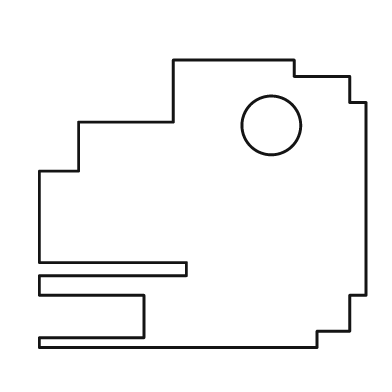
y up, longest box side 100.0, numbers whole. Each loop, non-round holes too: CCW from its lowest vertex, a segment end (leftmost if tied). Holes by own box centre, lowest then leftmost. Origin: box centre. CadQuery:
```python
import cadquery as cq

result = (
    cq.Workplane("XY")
    .moveTo(-50.0, -44.0)
    .lineTo(35.0, -44.0)
    .lineTo(35.0, -39.0)
    .lineTo(45.0, -39.0)
    .lineTo(45.0, -28.0)
    .lineTo(50.0, -28.0)
    .lineTo(50.0, 31.0)
    .lineTo(45.0, 31.0)
    .lineTo(45.0, 39.0)
    .lineTo(28.0, 39.0)
    .lineTo(28.0, 44.0)
    .lineTo(-9.0, 44.0)
    .lineTo(-9.0, 25.0)
    .lineTo(-38.0, 25.0)
    .lineTo(-38.0, 10.0)
    .lineTo(-50.0, 10.0)
    .lineTo(-50.0, -18.0)
    .lineTo(-5.0, -18.0)
    .lineTo(-5.0, -22.0)
    .lineTo(-50.0, -22.0)
    .lineTo(-50.0, -28.0)
    .lineTo(-18.0, -28.0)
    .lineTo(-18.0, -41.0)
    .lineTo(-50.0, -41.0)
    .close()
    .moveTo(21.0, 24.0)
    .circle(9.0)
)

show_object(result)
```